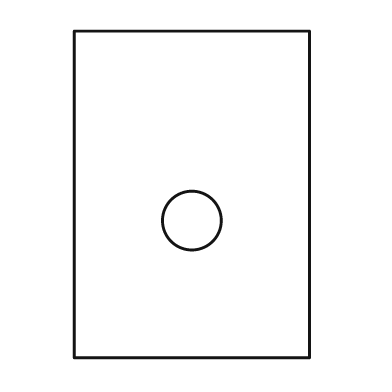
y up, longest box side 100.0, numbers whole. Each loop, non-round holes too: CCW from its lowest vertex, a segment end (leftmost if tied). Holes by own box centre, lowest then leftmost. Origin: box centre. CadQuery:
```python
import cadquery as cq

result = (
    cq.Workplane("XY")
    .moveTo(-36.0, -50.0)
    .lineTo(36.0, -50.0)
    .lineTo(36.0, 50.0)
    .lineTo(-36.0, 50.0)
    .close()
    .moveTo(0.0, -8.0)
    .circle(9.0)
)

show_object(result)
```